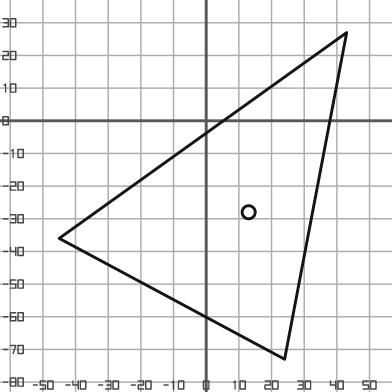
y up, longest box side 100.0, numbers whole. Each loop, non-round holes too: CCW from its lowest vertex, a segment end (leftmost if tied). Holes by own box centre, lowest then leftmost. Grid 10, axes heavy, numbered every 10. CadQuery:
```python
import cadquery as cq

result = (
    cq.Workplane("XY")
    .moveTo(24.0, -73.0)
    .lineTo(43.0, 27.0)
    .lineTo(-45.0, -36.0)
    .close()
    .moveTo(13.0, -28.0)
    .circle(2.0)
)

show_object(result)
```